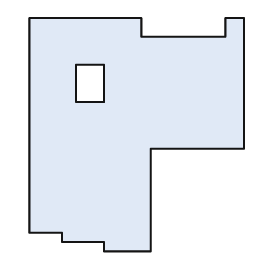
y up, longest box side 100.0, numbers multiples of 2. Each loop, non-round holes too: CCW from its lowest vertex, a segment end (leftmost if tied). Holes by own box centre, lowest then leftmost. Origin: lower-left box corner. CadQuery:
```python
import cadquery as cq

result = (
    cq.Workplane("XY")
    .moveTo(32.0, 0.0)
    .lineTo(52.0, 0.0)
    .lineTo(52.0, 44.0)
    .lineTo(92.0, 44.0)
    .lineTo(92.0, 100.0)
    .lineTo(84.0, 100.0)
    .lineTo(84.0, 92.0)
    .lineTo(48.0, 92.0)
    .lineTo(48.0, 100.0)
    .lineTo(0.0, 100.0)
    .lineTo(0.0, 8.0)
    .lineTo(14.0, 8.0)
    .lineTo(14.0, 4.0)
    .lineTo(32.0, 4.0)
    .close()
    .moveTo(20.0, 64.0)
    .lineTo(32.0, 64.0)
    .lineTo(32.0, 80.0)
    .lineTo(20.0, 80.0)
    .close()
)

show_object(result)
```